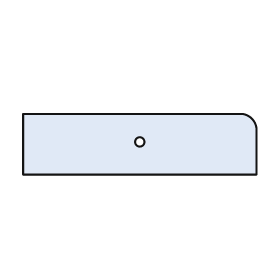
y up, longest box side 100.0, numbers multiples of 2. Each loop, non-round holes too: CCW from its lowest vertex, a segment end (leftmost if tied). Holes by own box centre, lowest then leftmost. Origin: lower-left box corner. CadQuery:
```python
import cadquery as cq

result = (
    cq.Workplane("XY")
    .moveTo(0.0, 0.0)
    .lineTo(100.0, 0.0)
    .lineTo(100.0, 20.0)
    .threePointArc((98.0, 24.0), (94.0, 26.0))
    .lineTo(0.0, 26.0)
    .close()
    .moveTo(50.0, 14.0)
    .circle(2.0)
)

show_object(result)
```